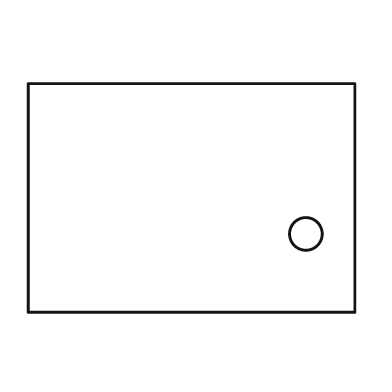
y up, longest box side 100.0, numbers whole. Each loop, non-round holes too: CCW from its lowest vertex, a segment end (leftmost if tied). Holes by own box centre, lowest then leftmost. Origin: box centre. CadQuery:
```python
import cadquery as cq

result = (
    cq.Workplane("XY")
    .moveTo(-50.0, -35.0)
    .lineTo(50.0, -35.0)
    .lineTo(50.0, 35.0)
    .lineTo(-50.0, 35.0)
    .close()
    .moveTo(35.0, -11.0)
    .circle(5.0)
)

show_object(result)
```